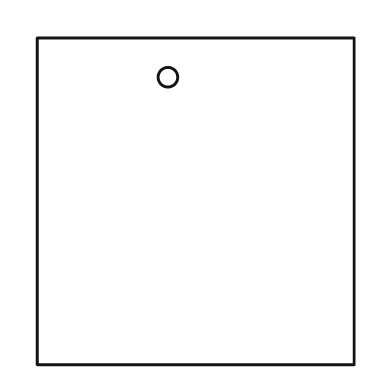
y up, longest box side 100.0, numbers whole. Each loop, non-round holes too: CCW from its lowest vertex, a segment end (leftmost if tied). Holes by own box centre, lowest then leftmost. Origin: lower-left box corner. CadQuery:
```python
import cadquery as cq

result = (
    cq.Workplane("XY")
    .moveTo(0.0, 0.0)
    .lineTo(97.0, 0.0)
    .lineTo(97.0, 100.0)
    .lineTo(0.0, 100.0)
    .close()
    .moveTo(40.0, 88.0)
    .circle(3.0)
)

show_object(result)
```